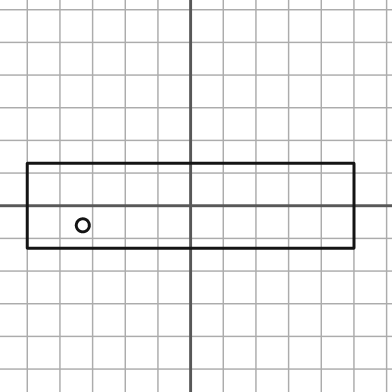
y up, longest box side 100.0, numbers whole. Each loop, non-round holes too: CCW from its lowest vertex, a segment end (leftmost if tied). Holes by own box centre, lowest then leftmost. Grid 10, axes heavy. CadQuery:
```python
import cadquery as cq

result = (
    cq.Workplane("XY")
    .moveTo(-50.0, -13.0)
    .lineTo(50.0, -13.0)
    .lineTo(50.0, 13.0)
    .lineTo(-50.0, 13.0)
    .close()
    .moveTo(-33.0, -6.0)
    .circle(2.0)
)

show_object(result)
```